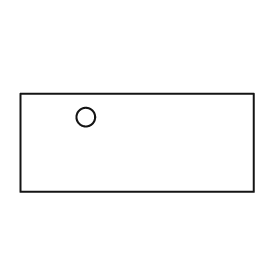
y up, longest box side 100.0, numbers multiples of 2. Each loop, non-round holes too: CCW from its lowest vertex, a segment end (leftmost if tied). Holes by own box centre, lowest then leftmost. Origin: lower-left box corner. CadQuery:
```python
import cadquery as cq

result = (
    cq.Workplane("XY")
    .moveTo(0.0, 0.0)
    .lineTo(100.0, 0.0)
    .lineTo(100.0, 42.0)
    .lineTo(0.0, 42.0)
    .close()
    .moveTo(28.0, 32.0)
    .circle(4.0)
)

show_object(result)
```